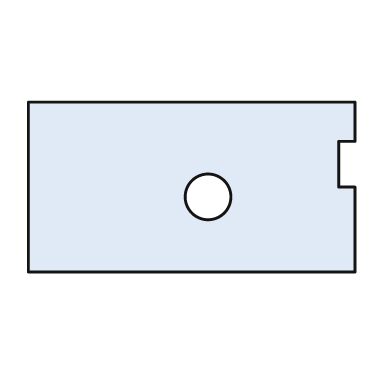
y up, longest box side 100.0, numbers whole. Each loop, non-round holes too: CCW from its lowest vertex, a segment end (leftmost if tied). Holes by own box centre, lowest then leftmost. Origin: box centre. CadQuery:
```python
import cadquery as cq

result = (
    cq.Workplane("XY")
    .moveTo(-50.0, -26.0)
    .lineTo(50.0, -26.0)
    .lineTo(50.0, 0.0)
    .lineTo(45.0, 0.0)
    .lineTo(45.0, 14.0)
    .lineTo(50.0, 14.0)
    .lineTo(50.0, 26.0)
    .lineTo(-50.0, 26.0)
    .close()
    .moveTo(5.0, -3.0)
    .circle(7.0)
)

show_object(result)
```